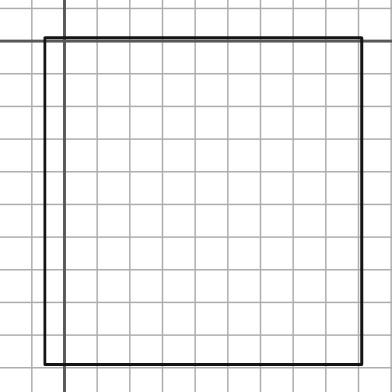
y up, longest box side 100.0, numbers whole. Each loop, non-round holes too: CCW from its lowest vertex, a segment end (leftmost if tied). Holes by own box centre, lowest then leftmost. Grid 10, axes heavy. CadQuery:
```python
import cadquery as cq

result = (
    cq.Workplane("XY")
    .moveTo(-6.0, -99.0)
    .lineTo(91.0, -99.0)
    .lineTo(91.0, 1.0)
    .lineTo(-6.0, 1.0)
    .close()
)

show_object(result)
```